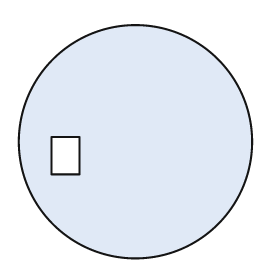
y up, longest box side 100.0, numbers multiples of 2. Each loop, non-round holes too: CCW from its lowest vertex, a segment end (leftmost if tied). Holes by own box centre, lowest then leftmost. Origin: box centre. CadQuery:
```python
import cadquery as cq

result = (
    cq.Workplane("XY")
    .moveTo(0.0, 0.0)
    .circle(50.0)
    .moveTo(-36.0, -14.0)
    .lineTo(-24.0, -14.0)
    .lineTo(-24.0, 2.0)
    .lineTo(-36.0, 2.0)
    .close()
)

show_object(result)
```